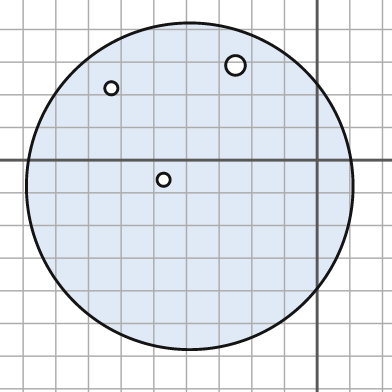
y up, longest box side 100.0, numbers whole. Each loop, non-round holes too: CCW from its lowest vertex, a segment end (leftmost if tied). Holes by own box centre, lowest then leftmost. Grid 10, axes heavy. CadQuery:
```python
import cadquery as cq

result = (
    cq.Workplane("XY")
    .moveTo(-39.0, -8.0)
    .circle(50.0)
    .moveTo(-47.0, -6.0)
    .circle(2.0)
    .moveTo(-63.0, 22.0)
    .circle(2.0)
    .moveTo(-25.0, 29.0)
    .circle(3.0)
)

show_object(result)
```